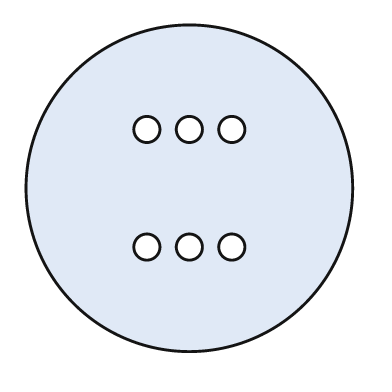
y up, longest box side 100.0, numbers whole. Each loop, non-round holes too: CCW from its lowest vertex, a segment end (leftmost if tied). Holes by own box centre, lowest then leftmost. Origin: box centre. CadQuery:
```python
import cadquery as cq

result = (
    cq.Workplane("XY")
    .moveTo(0.0, 0.0)
    .circle(50.0)
    .moveTo(-13.0, -18.0)
    .circle(4.0)
    .moveTo(0.0, -18.0)
    .circle(4.0)
    .moveTo(13.0, -18.0)
    .circle(4.0)
    .moveTo(-13.0, 18.0)
    .circle(4.0)
    .moveTo(0.0, 18.0)
    .circle(4.0)
    .moveTo(13.0, 18.0)
    .circle(4.0)
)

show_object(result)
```